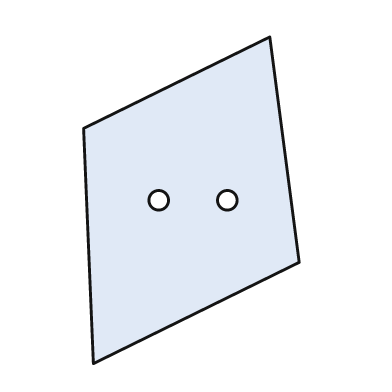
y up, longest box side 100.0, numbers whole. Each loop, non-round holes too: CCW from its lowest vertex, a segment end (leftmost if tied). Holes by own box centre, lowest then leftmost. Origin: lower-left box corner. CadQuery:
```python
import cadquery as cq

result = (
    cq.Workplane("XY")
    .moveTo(3.0, 0.0)
    .lineTo(66.0, 31.0)
    .lineTo(57.0, 100.0)
    .lineTo(0.0, 72.0)
    .close()
    .moveTo(23.0, 50.0)
    .circle(3.0)
    .moveTo(44.0, 50.0)
    .circle(3.0)
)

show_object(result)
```